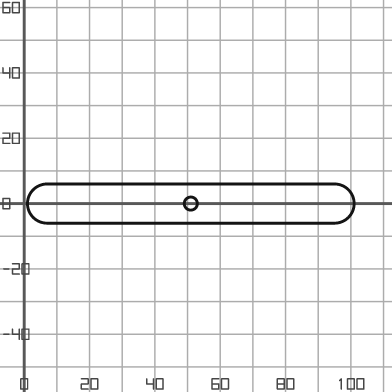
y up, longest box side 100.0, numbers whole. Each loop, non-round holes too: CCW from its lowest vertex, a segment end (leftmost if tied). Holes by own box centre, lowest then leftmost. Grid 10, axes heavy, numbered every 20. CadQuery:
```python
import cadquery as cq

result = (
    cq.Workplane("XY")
    .moveTo(7.0, -6.0)
    .lineTo(95.0, -6.0)
    .threePointArc((101.0, 0.0), (95.0, 6.0))
    .lineTo(7.0, 6.0)
    .threePointArc((1.0, 0.0), (7.0, -6.0))
    .close()
    .moveTo(51.0, 0.0)
    .circle(2.0)
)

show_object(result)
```